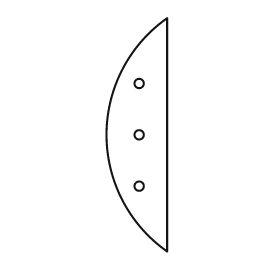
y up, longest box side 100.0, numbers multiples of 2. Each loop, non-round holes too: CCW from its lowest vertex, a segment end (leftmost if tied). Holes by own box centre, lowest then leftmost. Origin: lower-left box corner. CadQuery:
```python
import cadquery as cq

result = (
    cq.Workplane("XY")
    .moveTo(26.0, 0.0)
    .lineTo(26.0, 100.0)
    .threePointArc((0.0, 50.0), (26.0, 0.0))
    .close()
    .moveTo(14.0, 28.0)
    .circle(2.0)
    .moveTo(14.0, 50.0)
    .circle(2.0)
    .moveTo(14.0, 72.0)
    .circle(2.0)
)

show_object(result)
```